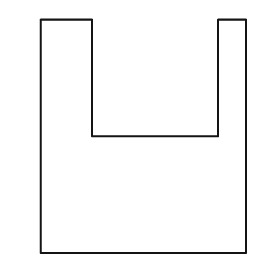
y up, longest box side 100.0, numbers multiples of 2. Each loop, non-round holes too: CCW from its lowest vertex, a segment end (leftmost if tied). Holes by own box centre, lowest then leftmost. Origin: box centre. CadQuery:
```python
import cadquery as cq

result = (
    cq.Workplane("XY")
    .moveTo(-44.0, -50.0)
    .lineTo(44.0, -50.0)
    .lineTo(44.0, 50.0)
    .lineTo(32.0, 50.0)
    .lineTo(32.0, 0.0)
    .lineTo(-22.0, 0.0)
    .lineTo(-22.0, 50.0)
    .lineTo(-44.0, 50.0)
    .close()
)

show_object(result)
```